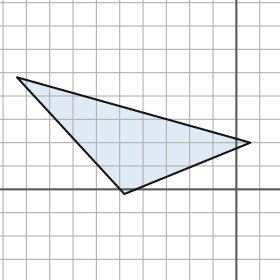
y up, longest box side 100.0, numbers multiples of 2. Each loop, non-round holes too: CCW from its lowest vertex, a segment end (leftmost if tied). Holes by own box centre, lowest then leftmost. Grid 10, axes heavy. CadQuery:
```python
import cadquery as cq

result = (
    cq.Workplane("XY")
    .moveTo(-48.0, -2.0)
    .lineTo(6.0, 20.0)
    .lineTo(-94.0, 48.0)
    .close()
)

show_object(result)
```